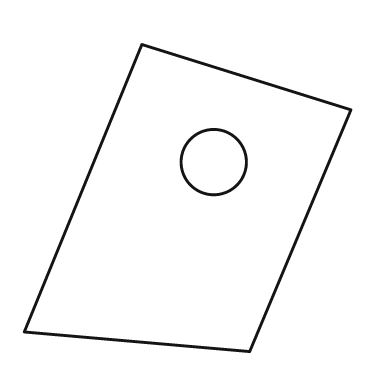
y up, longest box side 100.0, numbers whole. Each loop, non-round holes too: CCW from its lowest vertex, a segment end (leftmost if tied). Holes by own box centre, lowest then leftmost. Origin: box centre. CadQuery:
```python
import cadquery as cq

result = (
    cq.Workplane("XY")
    .moveTo(19.0, -47.0)
    .lineTo(50.0, 27.0)
    .lineTo(-14.0, 47.0)
    .lineTo(-50.0, -41.0)
    .close()
    .moveTo(8.0, 11.0)
    .circle(10.0)
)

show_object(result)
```